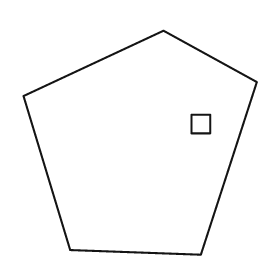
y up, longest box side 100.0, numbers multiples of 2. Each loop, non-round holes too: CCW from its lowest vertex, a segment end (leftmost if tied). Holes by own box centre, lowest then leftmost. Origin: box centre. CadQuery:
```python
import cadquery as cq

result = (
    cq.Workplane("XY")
    .moveTo(26.0, -48.0)
    .lineTo(50.0, 26.0)
    .lineTo(10.0, 48.0)
    .lineTo(-50.0, 20.0)
    .lineTo(-30.0, -46.0)
    .close()
    .moveTo(22.0, 4.0)
    .lineTo(30.0, 4.0)
    .lineTo(30.0, 12.0)
    .lineTo(22.0, 12.0)
    .close()
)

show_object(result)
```